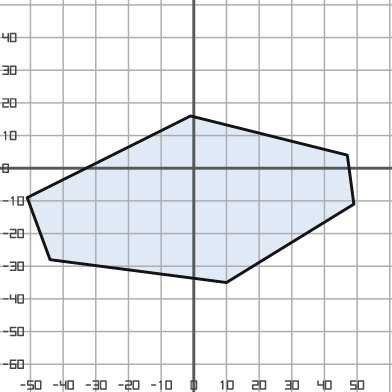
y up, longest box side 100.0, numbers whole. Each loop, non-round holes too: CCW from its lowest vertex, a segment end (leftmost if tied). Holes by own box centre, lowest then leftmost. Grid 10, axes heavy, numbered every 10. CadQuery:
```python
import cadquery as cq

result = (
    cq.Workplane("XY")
    .moveTo(10.0, -35.0)
    .lineTo(49.0, -11.0)
    .lineTo(47.0, 4.0)
    .lineTo(-1.0, 16.0)
    .lineTo(-51.0, -9.0)
    .lineTo(-44.0, -28.0)
    .close()
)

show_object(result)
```